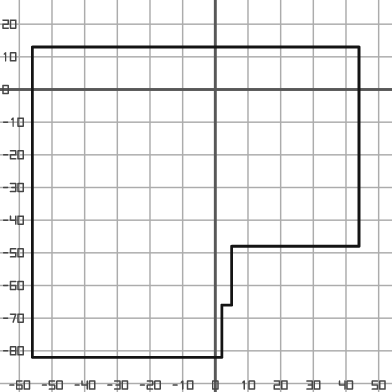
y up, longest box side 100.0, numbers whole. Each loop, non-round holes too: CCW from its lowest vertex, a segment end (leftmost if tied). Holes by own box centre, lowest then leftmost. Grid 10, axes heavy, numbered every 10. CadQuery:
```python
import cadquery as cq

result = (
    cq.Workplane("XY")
    .moveTo(-56.0, -82.0)
    .lineTo(2.0, -82.0)
    .lineTo(2.0, -66.0)
    .lineTo(5.0, -66.0)
    .lineTo(5.0, -48.0)
    .lineTo(44.0, -48.0)
    .lineTo(44.0, 13.0)
    .lineTo(-56.0, 13.0)
    .close()
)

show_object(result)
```